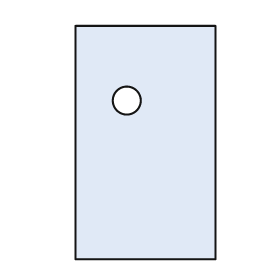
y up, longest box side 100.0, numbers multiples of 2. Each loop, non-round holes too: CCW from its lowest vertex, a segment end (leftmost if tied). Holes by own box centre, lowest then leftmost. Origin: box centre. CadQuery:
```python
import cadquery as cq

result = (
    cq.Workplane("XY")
    .moveTo(-30.0, -50.0)
    .lineTo(30.0, -50.0)
    .lineTo(30.0, 50.0)
    .lineTo(-30.0, 50.0)
    .close()
    .moveTo(-8.0, 18.0)
    .circle(6.0)
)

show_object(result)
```